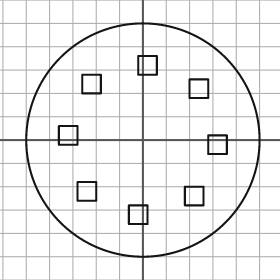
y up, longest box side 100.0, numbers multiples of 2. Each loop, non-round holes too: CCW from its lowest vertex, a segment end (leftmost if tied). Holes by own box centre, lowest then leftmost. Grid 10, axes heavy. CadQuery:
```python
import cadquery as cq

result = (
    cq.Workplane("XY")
    .moveTo(0.0, 0.0)
    .circle(50.0)
    .moveTo(-6.0, -36.0)
    .lineTo(2.0, -36.0)
    .lineTo(2.0, -28.0)
    .lineTo(-6.0, -28.0)
    .close()
    .moveTo(18.0, -28.0)
    .lineTo(26.0, -28.0)
    .lineTo(26.0, -20.0)
    .lineTo(18.0, -20.0)
    .close()
    .moveTo(-28.0, -26.0)
    .lineTo(-20.0, -26.0)
    .lineTo(-20.0, -18.0)
    .lineTo(-28.0, -18.0)
    .close()
    .moveTo(28.0, -6.0)
    .lineTo(36.0, -6.0)
    .lineTo(36.0, 2.0)
    .lineTo(28.0, 2.0)
    .close()
    .moveTo(-36.0, -2.0)
    .lineTo(-28.0, -2.0)
    .lineTo(-28.0, 6.0)
    .lineTo(-36.0, 6.0)
    .close()
    .moveTo(20.0, 18.0)
    .lineTo(28.0, 18.0)
    .lineTo(28.0, 26.0)
    .lineTo(20.0, 26.0)
    .close()
    .moveTo(-26.0, 20.0)
    .lineTo(-18.0, 20.0)
    .lineTo(-18.0, 28.0)
    .lineTo(-26.0, 28.0)
    .close()
    .moveTo(-2.0, 28.0)
    .lineTo(6.0, 28.0)
    .lineTo(6.0, 36.0)
    .lineTo(-2.0, 36.0)
    .close()
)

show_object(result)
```